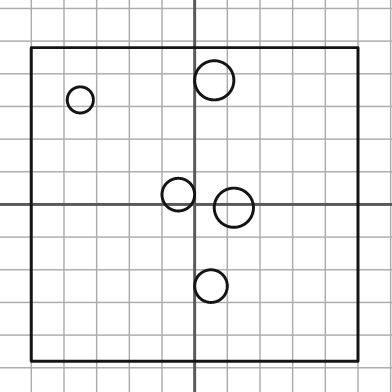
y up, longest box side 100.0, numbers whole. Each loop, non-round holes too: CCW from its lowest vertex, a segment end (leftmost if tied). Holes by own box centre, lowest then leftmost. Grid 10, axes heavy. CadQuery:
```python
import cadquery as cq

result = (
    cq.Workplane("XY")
    .moveTo(-50.0, -48.0)
    .lineTo(50.0, -48.0)
    .lineTo(50.0, 48.0)
    .lineTo(-50.0, 48.0)
    .close()
    .moveTo(5.0, -25.0)
    .circle(5.0)
    .moveTo(12.0, -1.0)
    .circle(6.0)
    .moveTo(-5.0, 3.0)
    .circle(5.0)
    .moveTo(-35.0, 32.0)
    .circle(4.0)
    .moveTo(6.0, 38.0)
    .circle(6.0)
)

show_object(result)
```